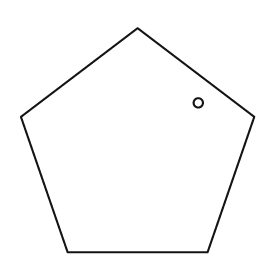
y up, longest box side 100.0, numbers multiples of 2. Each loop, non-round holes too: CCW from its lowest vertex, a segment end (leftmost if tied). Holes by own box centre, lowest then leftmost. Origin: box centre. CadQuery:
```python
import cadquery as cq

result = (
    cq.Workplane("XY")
    .moveTo(-30.0, -48.0)
    .lineTo(30.0, -48.0)
    .lineTo(50.0, 10.0)
    .lineTo(0.0, 48.0)
    .lineTo(-50.0, 10.0)
    .close()
    .moveTo(26.0, 16.0)
    .circle(2.0)
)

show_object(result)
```